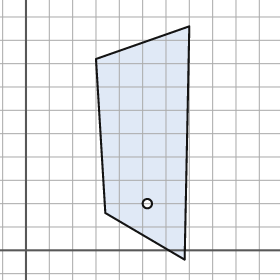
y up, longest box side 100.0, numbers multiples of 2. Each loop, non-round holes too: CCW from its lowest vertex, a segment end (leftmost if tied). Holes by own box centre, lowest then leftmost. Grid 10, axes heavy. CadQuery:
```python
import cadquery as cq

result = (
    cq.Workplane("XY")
    .moveTo(68.0, -4.0)
    .lineTo(70.0, 96.0)
    .lineTo(30.0, 82.0)
    .lineTo(34.0, 16.0)
    .close()
    .moveTo(52.0, 20.0)
    .circle(2.0)
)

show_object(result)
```